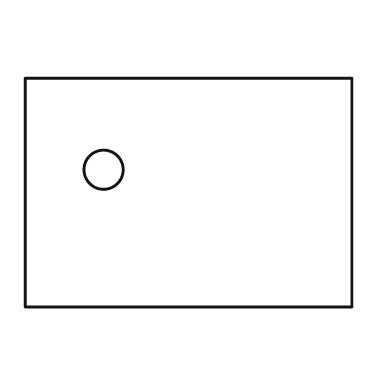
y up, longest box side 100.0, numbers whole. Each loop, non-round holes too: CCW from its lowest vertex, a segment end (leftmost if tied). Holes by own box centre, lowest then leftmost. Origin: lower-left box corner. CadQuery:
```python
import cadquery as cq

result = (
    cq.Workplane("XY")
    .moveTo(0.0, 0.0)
    .lineTo(100.0, 0.0)
    .lineTo(100.0, 70.0)
    .lineTo(0.0, 70.0)
    .close()
    .moveTo(24.0, 42.0)
    .circle(6.0)
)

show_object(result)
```